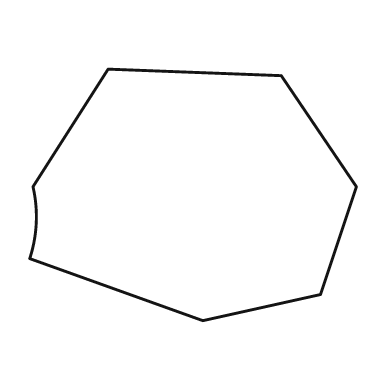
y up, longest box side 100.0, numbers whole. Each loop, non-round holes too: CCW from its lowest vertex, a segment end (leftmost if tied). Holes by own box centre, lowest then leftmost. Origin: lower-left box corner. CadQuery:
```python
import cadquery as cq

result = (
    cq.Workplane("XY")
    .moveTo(53.0, 0.0)
    .lineTo(89.0, 8.0)
    .lineTo(100.0, 41.0)
    .lineTo(77.0, 75.0)
    .lineTo(24.0, 77.0)
    .lineTo(1.0, 41.0)
    .threePointArc((2.0, 30.0), (0.0, 19.0))
    .close()
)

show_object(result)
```